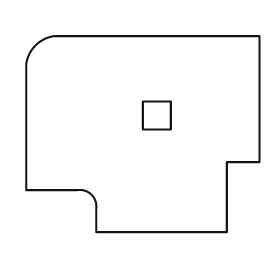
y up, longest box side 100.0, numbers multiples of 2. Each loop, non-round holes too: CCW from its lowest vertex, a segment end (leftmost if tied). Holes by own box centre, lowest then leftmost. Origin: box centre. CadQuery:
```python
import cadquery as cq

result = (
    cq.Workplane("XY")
    .moveTo(-20.0, -42.0)
    .lineTo(36.0, -42.0)
    .lineTo(36.0, -12.0)
    .lineTo(50.0, -12.0)
    .lineTo(50.0, 42.0)
    .lineTo(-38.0, 42.0)
    .threePointArc((-46.0, 38.0), (-50.0, 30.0))
    .lineTo(-50.0, -24.0)
    .lineTo(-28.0, -24.0)
    .threePointArc((-22.0, -26.0), (-20.0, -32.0))
    .close()
    .moveTo(0.0, 2.0)
    .lineTo(12.0, 2.0)
    .lineTo(12.0, 14.0)
    .lineTo(0.0, 14.0)
    .close()
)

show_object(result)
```